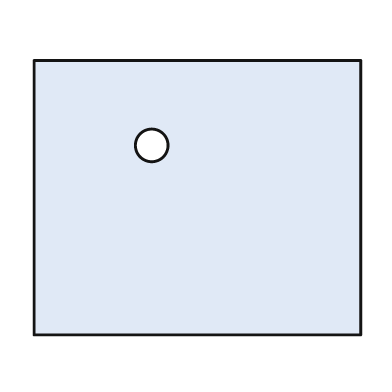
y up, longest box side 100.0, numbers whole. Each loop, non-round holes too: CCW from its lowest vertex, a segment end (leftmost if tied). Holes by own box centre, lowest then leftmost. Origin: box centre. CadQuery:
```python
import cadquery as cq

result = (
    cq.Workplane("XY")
    .moveTo(-50.0, -42.0)
    .lineTo(50.0, -42.0)
    .lineTo(50.0, 42.0)
    .lineTo(-50.0, 42.0)
    .close()
    .moveTo(-14.0, 16.0)
    .circle(5.0)
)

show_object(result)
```